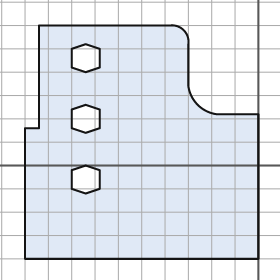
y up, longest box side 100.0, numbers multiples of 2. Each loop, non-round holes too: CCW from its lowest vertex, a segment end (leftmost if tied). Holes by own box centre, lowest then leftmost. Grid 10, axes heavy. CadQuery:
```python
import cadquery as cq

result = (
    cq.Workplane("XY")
    .moveTo(-100.0, -40.0)
    .lineTo(0.0, -40.0)
    .lineTo(0.0, 22.0)
    .lineTo(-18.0, 22.0)
    .threePointArc((-26.0, 26.0), (-30.0, 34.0))
    .lineTo(-30.0, 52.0)
    .threePointArc((-32.0, 58.0), (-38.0, 60.0))
    .lineTo(-94.0, 60.0)
    .lineTo(-94.0, 16.0)
    .lineTo(-100.0, 16.0)
    .close()
    .moveTo(-74.0, -12.0)
    .lineTo(-68.0, -10.0)
    .lineTo(-68.0, -2.0)
    .lineTo(-74.0, 0.0)
    .lineTo(-80.0, -2.0)
    .lineTo(-80.0, -10.0)
    .close()
    .moveTo(-74.0, 14.0)
    .lineTo(-68.0, 16.0)
    .lineTo(-68.0, 24.0)
    .lineTo(-74.0, 26.0)
    .lineTo(-80.0, 24.0)
    .lineTo(-80.0, 16.0)
    .close()
    .moveTo(-74.0, 40.0)
    .lineTo(-68.0, 42.0)
    .lineTo(-68.0, 50.0)
    .lineTo(-74.0, 52.0)
    .lineTo(-80.0, 50.0)
    .lineTo(-80.0, 42.0)
    .close()
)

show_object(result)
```